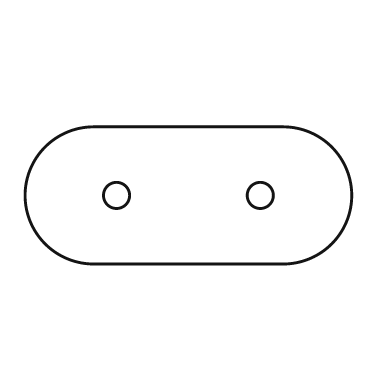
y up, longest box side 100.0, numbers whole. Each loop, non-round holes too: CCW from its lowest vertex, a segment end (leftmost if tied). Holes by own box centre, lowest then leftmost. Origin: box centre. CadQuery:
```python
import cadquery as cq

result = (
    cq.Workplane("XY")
    .moveTo(-29.0, -21.0)
    .lineTo(29.0, -21.0)
    .threePointArc((50.0, 0.0), (29.0, 21.0))
    .lineTo(-29.0, 21.0)
    .threePointArc((-50.0, 0.0), (-29.0, -21.0))
    .close()
    .moveTo(-22.0, 0.0)
    .circle(4.0)
    .moveTo(22.0, 0.0)
    .circle(4.0)
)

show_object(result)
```